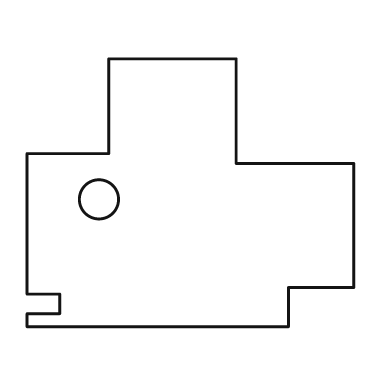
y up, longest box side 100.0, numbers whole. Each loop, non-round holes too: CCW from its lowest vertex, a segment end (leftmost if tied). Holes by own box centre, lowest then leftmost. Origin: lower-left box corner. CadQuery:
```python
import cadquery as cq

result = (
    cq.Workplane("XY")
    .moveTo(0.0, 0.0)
    .lineTo(80.0, 0.0)
    .lineTo(80.0, 12.0)
    .lineTo(100.0, 12.0)
    .lineTo(100.0, 50.0)
    .lineTo(64.0, 50.0)
    .lineTo(64.0, 82.0)
    .lineTo(25.0, 82.0)
    .lineTo(25.0, 53.0)
    .lineTo(0.0, 53.0)
    .lineTo(0.0, 10.0)
    .lineTo(10.0, 10.0)
    .lineTo(10.0, 4.0)
    .lineTo(0.0, 4.0)
    .close()
    .moveTo(22.0, 39.0)
    .circle(6.0)
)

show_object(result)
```